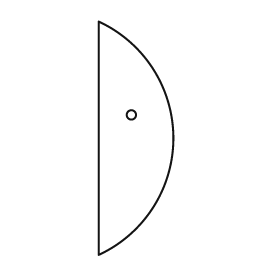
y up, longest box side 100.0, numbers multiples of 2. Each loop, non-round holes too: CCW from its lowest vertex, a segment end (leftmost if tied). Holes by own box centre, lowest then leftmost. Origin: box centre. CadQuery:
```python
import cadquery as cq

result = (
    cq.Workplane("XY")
    .moveTo(-16.0, -50.0)
    .threePointArc((16.0, 0.0), (-16.0, 50.0))
    .close()
    .moveTo(-2.0, 10.0)
    .circle(2.0)
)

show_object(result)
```